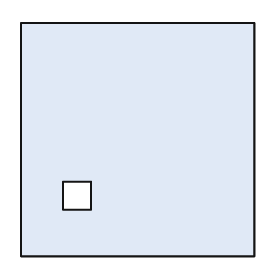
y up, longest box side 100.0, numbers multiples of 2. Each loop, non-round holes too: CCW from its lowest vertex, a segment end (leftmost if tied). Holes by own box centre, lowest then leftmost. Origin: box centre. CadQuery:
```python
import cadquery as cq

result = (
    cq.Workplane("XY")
    .moveTo(-50.0, -50.0)
    .lineTo(50.0, -50.0)
    .lineTo(50.0, 50.0)
    .lineTo(-50.0, 50.0)
    .close()
    .moveTo(-32.0, -30.0)
    .lineTo(-20.0, -30.0)
    .lineTo(-20.0, -18.0)
    .lineTo(-32.0, -18.0)
    .close()
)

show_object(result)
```